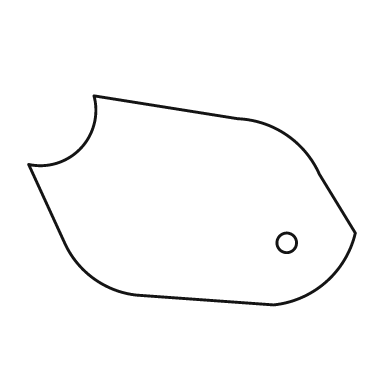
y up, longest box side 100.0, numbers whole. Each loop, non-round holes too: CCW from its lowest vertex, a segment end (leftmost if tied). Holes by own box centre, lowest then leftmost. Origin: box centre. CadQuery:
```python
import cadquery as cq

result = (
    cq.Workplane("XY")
    .moveTo(25.0, -32.0)
    .threePointArc((41.0, -25.0), (50.0, -10.0))
    .lineTo(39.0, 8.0)
    .threePointArc((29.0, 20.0), (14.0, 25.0))
    .lineTo(-30.0, 32.0)
    .threePointArc((-34.0, 16.0), (-50.0, 11.0))
    .lineTo(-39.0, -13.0)
    .threePointArc((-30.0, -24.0), (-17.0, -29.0))
    .close()
    .moveTo(29.0, -13.0)
    .circle(3.0)
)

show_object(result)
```